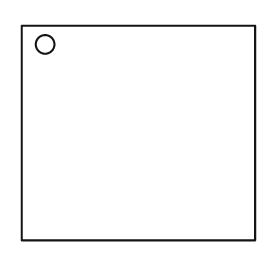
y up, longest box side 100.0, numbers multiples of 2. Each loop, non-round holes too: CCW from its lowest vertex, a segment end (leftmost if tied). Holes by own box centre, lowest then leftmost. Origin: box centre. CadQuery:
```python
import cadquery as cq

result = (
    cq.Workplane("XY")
    .moveTo(-50.0, -46.0)
    .lineTo(50.0, -46.0)
    .lineTo(50.0, 46.0)
    .lineTo(-50.0, 46.0)
    .close()
    .moveTo(-40.0, 38.0)
    .circle(4.0)
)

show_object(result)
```